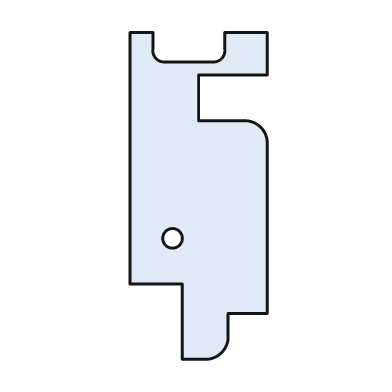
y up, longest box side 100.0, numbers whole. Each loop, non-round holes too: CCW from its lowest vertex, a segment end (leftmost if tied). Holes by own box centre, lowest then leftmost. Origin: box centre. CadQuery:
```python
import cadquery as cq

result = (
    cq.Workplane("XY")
    .moveTo(-5.0, -50.0)
    .lineTo(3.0, -50.0)
    .threePointArc((7.0, -48.0), (9.0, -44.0))
    .lineTo(9.0, -36.0)
    .lineTo(21.0, -36.0)
    .lineTo(21.0, 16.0)
    .threePointArc((19.0, 21.0), (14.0, 23.0))
    .lineTo(0.0, 23.0)
    .lineTo(0.0, 37.0)
    .lineTo(21.0, 37.0)
    .lineTo(21.0, 50.0)
    .lineTo(8.0, 50.0)
    .lineTo(8.0, 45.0)
    .threePointArc((7.0, 42.0), (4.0, 41.0))
    .lineTo(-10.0, 41.0)
    .threePointArc((-13.0, 42.0), (-14.0, 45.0))
    .lineTo(-14.0, 50.0)
    .lineTo(-21.0, 50.0)
    .lineTo(-21.0, -27.0)
    .lineTo(-5.0, -27.0)
    .close()
    .moveTo(-8.0, -13.0)
    .circle(3.0)
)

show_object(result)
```